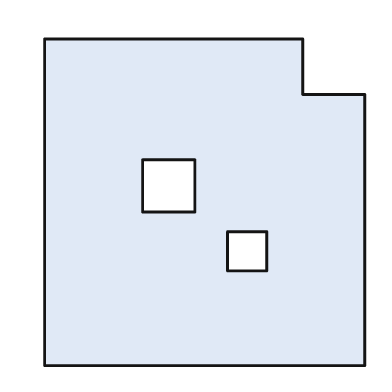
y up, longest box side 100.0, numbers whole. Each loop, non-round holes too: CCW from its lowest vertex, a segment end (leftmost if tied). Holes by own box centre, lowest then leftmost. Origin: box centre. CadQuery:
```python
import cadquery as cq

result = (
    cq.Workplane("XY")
    .moveTo(-49.0, -50.0)
    .lineTo(49.0, -50.0)
    .lineTo(49.0, 33.0)
    .lineTo(30.0, 33.0)
    .lineTo(30.0, 50.0)
    .lineTo(-49.0, 50.0)
    .close()
    .moveTo(7.0, -21.0)
    .lineTo(19.0, -21.0)
    .lineTo(19.0, -9.0)
    .lineTo(7.0, -9.0)
    .close()
    .moveTo(-19.0, -3.0)
    .lineTo(-3.0, -3.0)
    .lineTo(-3.0, 13.0)
    .lineTo(-19.0, 13.0)
    .close()
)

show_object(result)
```